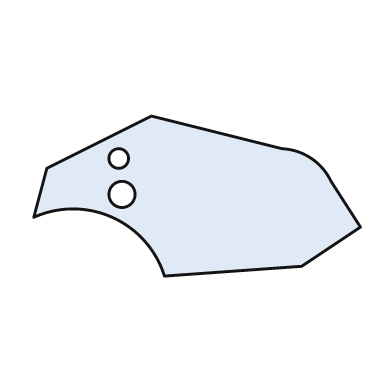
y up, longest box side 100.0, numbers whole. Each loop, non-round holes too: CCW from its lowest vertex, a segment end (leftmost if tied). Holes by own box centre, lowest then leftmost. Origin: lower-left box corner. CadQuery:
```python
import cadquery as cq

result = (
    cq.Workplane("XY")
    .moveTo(40.0, 0.0)
    .lineTo(82.0, 3.0)
    .lineTo(100.0, 15.0)
    .lineTo(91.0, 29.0)
    .threePointArc((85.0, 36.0), (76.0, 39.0))
    .lineTo(36.0, 49.0)
    .lineTo(4.0, 33.0)
    .lineTo(0.0, 18.0)
    .threePointArc((24.0, 18.0), (40.0, 0.0))
    .close()
    .moveTo(27.0, 25.0)
    .circle(4.0)
    .moveTo(26.0, 36.0)
    .circle(3.0)
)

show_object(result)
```